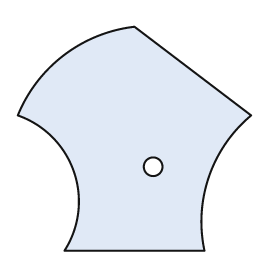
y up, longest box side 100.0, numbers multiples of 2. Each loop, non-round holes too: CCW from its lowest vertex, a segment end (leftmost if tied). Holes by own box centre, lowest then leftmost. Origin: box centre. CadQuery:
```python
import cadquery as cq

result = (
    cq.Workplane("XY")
    .moveTo(-30.0, -48.0)
    .lineTo(30.0, -48.0)
    .threePointArc((32.0, -16.0), (50.0, 10.0))
    .lineTo(0.0, 48.0)
    .threePointArc((-30.0, 36.0), (-50.0, 10.0))
    .threePointArc((-26.0, -14.0), (-30.0, -48.0))
    .close()
    .moveTo(8.0, -12.0)
    .circle(4.0)
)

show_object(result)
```